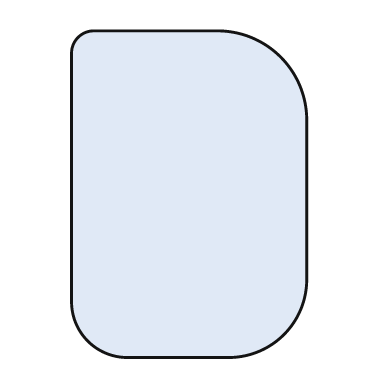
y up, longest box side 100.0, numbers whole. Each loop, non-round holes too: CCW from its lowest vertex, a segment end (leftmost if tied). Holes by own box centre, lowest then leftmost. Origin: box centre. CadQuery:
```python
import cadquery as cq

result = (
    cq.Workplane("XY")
    .moveTo(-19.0, -50.0)
    .lineTo(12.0, -50.0)
    .threePointArc((29.0, -43.0), (36.0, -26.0))
    .lineTo(36.0, 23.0)
    .threePointArc((28.0, 42.0), (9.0, 50.0))
    .lineTo(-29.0, 50.0)
    .threePointArc((-34.0, 48.0), (-36.0, 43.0))
    .lineTo(-36.0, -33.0)
    .threePointArc((-31.0, -45.0), (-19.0, -50.0))
    .close()
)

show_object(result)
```